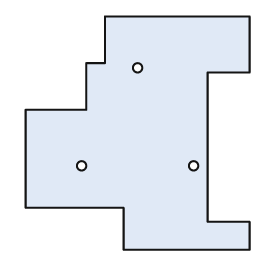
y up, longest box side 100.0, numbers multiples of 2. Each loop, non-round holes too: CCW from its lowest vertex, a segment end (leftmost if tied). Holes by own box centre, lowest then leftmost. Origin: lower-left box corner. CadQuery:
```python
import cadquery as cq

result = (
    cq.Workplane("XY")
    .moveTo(42.0, 0.0)
    .lineTo(96.0, 0.0)
    .lineTo(96.0, 12.0)
    .lineTo(78.0, 12.0)
    .lineTo(78.0, 76.0)
    .lineTo(96.0, 76.0)
    .lineTo(96.0, 100.0)
    .lineTo(34.0, 100.0)
    .lineTo(34.0, 80.0)
    .lineTo(26.0, 80.0)
    .lineTo(26.0, 60.0)
    .lineTo(0.0, 60.0)
    .lineTo(0.0, 18.0)
    .lineTo(42.0, 18.0)
    .close()
    .moveTo(24.0, 36.0)
    .circle(2.0)
    .moveTo(72.0, 36.0)
    .circle(2.0)
    .moveTo(48.0, 78.0)
    .circle(2.0)
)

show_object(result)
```